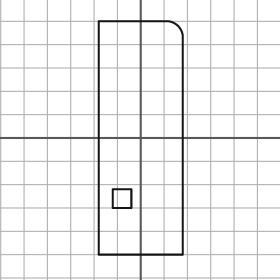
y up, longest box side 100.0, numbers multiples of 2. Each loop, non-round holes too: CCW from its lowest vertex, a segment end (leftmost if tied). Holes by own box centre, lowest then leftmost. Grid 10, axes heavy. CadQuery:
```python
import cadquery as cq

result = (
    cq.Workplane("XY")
    .moveTo(-18.0, -50.0)
    .lineTo(18.0, -50.0)
    .lineTo(18.0, 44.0)
    .threePointArc((16.0, 48.0), (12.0, 50.0))
    .lineTo(-18.0, 50.0)
    .close()
    .moveTo(-12.0, -30.0)
    .lineTo(-4.0, -30.0)
    .lineTo(-4.0, -22.0)
    .lineTo(-12.0, -22.0)
    .close()
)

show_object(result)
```